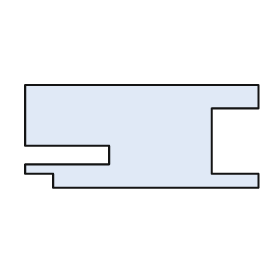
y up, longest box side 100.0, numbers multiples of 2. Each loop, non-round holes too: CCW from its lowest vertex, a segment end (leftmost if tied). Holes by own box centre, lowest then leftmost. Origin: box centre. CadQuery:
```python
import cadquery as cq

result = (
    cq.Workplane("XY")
    .moveTo(-38.0, -22.0)
    .lineTo(50.0, -22.0)
    .lineTo(50.0, -16.0)
    .lineTo(30.0, -16.0)
    .lineTo(30.0, 12.0)
    .lineTo(50.0, 12.0)
    .lineTo(50.0, 22.0)
    .lineTo(-50.0, 22.0)
    .lineTo(-50.0, -4.0)
    .lineTo(-14.0, -4.0)
    .lineTo(-14.0, -12.0)
    .lineTo(-50.0, -12.0)
    .lineTo(-50.0, -16.0)
    .lineTo(-38.0, -16.0)
    .close()
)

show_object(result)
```